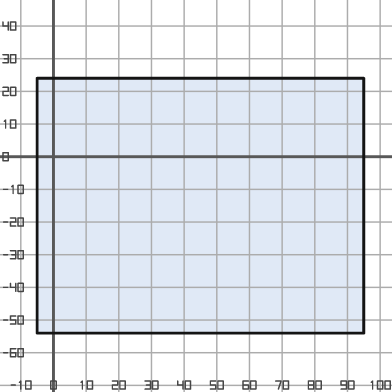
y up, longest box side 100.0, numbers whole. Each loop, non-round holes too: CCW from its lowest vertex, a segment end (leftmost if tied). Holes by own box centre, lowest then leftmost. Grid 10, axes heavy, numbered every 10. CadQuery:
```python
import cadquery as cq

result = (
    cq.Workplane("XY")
    .moveTo(-5.0, -54.0)
    .lineTo(95.0, -54.0)
    .lineTo(95.0, 24.0)
    .lineTo(-5.0, 24.0)
    .close()
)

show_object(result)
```